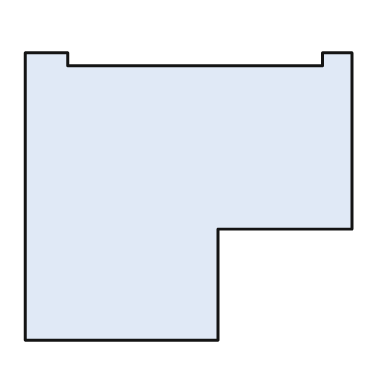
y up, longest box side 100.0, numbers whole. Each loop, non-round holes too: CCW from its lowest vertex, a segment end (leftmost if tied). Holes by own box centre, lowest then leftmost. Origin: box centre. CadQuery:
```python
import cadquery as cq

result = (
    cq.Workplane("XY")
    .moveTo(-50.0, -44.0)
    .lineTo(9.0, -44.0)
    .lineTo(9.0, -10.0)
    .lineTo(50.0, -10.0)
    .lineTo(50.0, 44.0)
    .lineTo(41.0, 44.0)
    .lineTo(41.0, 40.0)
    .lineTo(-37.0, 40.0)
    .lineTo(-37.0, 44.0)
    .lineTo(-50.0, 44.0)
    .close()
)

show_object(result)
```